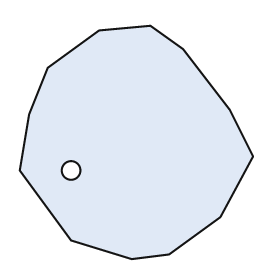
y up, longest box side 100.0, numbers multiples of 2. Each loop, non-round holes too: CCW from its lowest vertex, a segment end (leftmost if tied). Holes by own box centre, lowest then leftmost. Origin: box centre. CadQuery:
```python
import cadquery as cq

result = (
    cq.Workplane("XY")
    .moveTo(-2.0, -50.0)
    .lineTo(14.0, -48.0)
    .lineTo(36.0, -32.0)
    .lineTo(50.0, -6.0)
    .lineTo(40.0, 14.0)
    .lineTo(20.0, 40.0)
    .lineTo(6.0, 50.0)
    .lineTo(-16.0, 48.0)
    .lineTo(-38.0, 32.0)
    .lineTo(-46.0, 12.0)
    .lineTo(-50.0, -12.0)
    .lineTo(-28.0, -42.0)
    .close()
    .moveTo(-28.0, -12.0)
    .circle(4.0)
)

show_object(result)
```